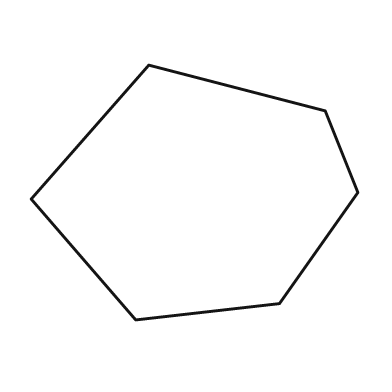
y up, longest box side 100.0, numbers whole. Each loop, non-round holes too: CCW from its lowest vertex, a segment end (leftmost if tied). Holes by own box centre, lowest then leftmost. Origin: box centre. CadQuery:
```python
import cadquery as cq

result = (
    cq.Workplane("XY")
    .moveTo(-18.0, -39.0)
    .lineTo(26.0, -34.0)
    .lineTo(50.0, 0.0)
    .lineTo(40.0, 25.0)
    .lineTo(-14.0, 39.0)
    .lineTo(-50.0, -2.0)
    .close()
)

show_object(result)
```